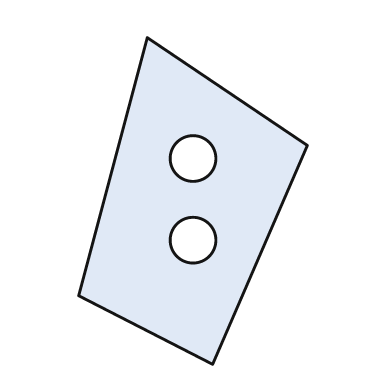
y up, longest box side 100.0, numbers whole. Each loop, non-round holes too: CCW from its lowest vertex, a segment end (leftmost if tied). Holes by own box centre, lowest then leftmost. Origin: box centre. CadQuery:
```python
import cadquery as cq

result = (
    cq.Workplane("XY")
    .moveTo(6.0, -50.0)
    .lineTo(35.0, 17.0)
    .lineTo(-14.0, 50.0)
    .lineTo(-35.0, -29.0)
    .close()
    .moveTo(0.0, -12.0)
    .circle(7.0)
    .moveTo(0.0, 13.0)
    .circle(7.0)
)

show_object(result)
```